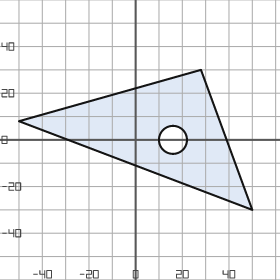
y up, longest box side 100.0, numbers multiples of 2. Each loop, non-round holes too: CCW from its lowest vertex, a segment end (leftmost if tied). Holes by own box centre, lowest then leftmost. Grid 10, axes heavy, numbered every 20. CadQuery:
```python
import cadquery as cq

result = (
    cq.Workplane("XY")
    .moveTo(50.0, -30.0)
    .lineTo(28.0, 30.0)
    .lineTo(-50.0, 8.0)
    .close()
    .moveTo(16.0, 0.0)
    .circle(6.0)
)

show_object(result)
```